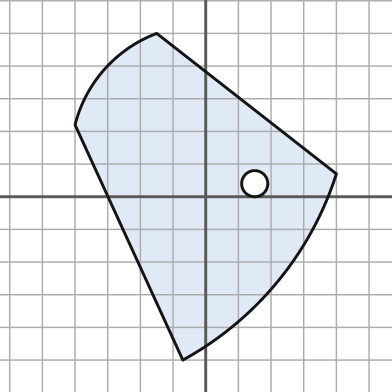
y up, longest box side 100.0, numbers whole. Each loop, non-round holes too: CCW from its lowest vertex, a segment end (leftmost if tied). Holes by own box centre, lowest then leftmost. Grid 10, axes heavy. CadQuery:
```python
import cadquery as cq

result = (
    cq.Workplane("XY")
    .moveTo(-7.0, -50.0)
    .threePointArc((22.0, -26.0), (40.0, 7.0))
    .lineTo(-15.0, 50.0)
    .threePointArc((-31.0, 39.0), (-40.0, 22.0))
    .close()
    .moveTo(15.0, 4.0)
    .circle(4.0)
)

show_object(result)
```